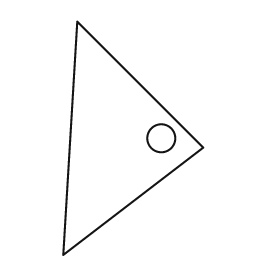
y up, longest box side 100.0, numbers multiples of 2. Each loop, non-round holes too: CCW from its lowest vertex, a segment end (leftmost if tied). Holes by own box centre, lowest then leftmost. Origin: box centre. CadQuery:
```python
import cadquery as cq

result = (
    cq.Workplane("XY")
    .moveTo(-30.0, -50.0)
    .lineTo(30.0, -4.0)
    .lineTo(-24.0, 50.0)
    .close()
    .moveTo(12.0, 0.0)
    .circle(6.0)
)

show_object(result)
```